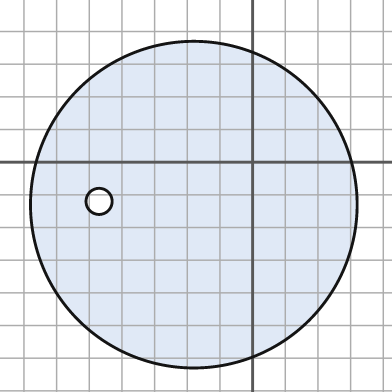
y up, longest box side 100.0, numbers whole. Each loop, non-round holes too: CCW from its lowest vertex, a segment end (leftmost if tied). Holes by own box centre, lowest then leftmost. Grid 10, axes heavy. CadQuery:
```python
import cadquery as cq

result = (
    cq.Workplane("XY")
    .moveTo(-18.0, -13.0)
    .circle(50.0)
    .moveTo(-47.0, -12.0)
    .circle(4.0)
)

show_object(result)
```